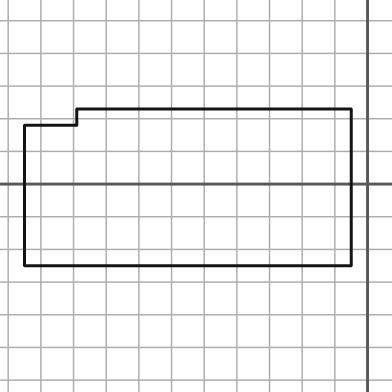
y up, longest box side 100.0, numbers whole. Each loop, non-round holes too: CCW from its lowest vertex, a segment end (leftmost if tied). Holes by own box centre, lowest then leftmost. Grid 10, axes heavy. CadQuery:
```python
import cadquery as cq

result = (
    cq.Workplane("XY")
    .moveTo(-105.0, -25.0)
    .lineTo(-5.0, -25.0)
    .lineTo(-5.0, 23.0)
    .lineTo(-89.0, 23.0)
    .lineTo(-89.0, 18.0)
    .lineTo(-105.0, 18.0)
    .close()
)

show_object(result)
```